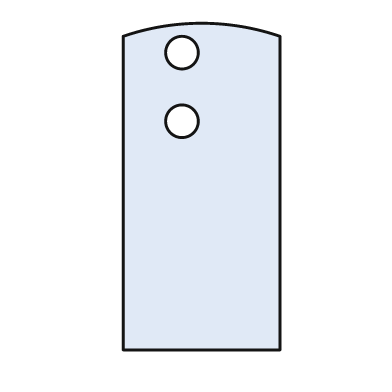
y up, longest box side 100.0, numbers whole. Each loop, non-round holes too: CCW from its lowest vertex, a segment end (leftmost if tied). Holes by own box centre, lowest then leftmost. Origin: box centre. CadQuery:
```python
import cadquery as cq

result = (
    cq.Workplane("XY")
    .moveTo(-24.0, -50.0)
    .lineTo(24.0, -50.0)
    .lineTo(24.0, 46.0)
    .threePointArc((0.0, 50.0), (-24.0, 46.0))
    .close()
    .moveTo(-6.0, 20.0)
    .circle(5.0)
    .moveTo(-6.0, 41.0)
    .circle(5.0)
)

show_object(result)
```